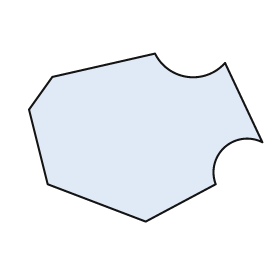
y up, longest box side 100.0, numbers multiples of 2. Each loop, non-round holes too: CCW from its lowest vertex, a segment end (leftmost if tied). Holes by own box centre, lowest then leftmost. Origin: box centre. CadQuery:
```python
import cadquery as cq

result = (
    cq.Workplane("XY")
    .moveTo(0.0, -36.0)
    .lineTo(30.0, -20.0)
    .threePointArc((34.0, -4.0), (50.0, -2.0))
    .lineTo(34.0, 32.0)
    .threePointArc((18.0, 26.0), (4.0, 36.0))
    .lineTo(-40.0, 26.0)
    .lineTo(-50.0, 12.0)
    .lineTo(-42.0, -20.0)
    .close()
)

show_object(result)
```